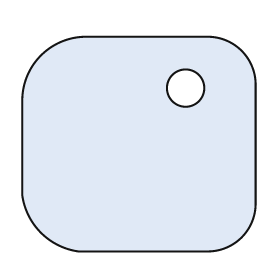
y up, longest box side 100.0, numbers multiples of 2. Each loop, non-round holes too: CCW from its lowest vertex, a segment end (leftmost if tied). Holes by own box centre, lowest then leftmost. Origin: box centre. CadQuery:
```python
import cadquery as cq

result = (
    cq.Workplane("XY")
    .moveTo(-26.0, -46.0)
    .lineTo(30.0, -46.0)
    .threePointArc((44.0, -40.0), (50.0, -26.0))
    .lineTo(50.0, 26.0)
    .threePointArc((44.0, 40.0), (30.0, 46.0))
    .lineTo(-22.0, 46.0)
    .threePointArc((-42.0, 38.0), (-50.0, 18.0))
    .lineTo(-50.0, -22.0)
    .threePointArc((-42.0, -38.0), (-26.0, -46.0))
    .close()
    .moveTo(20.0, 24.0)
    .circle(8.0)
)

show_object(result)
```